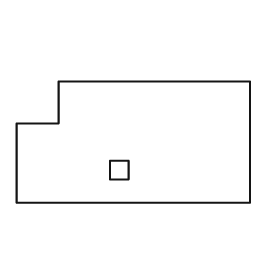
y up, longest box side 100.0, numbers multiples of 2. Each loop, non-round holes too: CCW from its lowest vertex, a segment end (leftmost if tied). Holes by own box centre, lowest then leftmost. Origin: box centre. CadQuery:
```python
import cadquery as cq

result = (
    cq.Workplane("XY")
    .moveTo(-50.0, -26.0)
    .lineTo(50.0, -26.0)
    .lineTo(50.0, 26.0)
    .lineTo(-32.0, 26.0)
    .lineTo(-32.0, 8.0)
    .lineTo(-50.0, 8.0)
    .close()
    .moveTo(-10.0, -16.0)
    .lineTo(-2.0, -16.0)
    .lineTo(-2.0, -8.0)
    .lineTo(-10.0, -8.0)
    .close()
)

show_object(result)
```